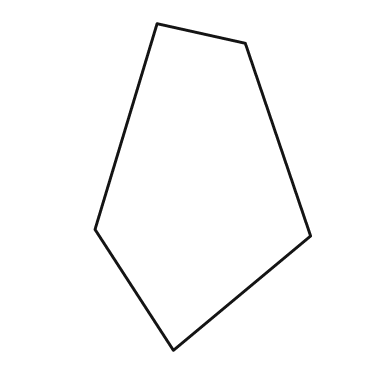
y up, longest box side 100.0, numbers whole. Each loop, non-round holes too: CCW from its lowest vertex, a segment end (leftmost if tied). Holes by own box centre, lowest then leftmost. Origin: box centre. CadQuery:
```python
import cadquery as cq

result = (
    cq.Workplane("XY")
    .moveTo(-9.0, -50.0)
    .lineTo(33.0, -15.0)
    .lineTo(13.0, 44.0)
    .lineTo(-14.0, 50.0)
    .lineTo(-33.0, -13.0)
    .close()
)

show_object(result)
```